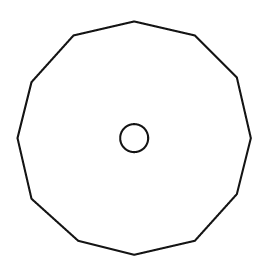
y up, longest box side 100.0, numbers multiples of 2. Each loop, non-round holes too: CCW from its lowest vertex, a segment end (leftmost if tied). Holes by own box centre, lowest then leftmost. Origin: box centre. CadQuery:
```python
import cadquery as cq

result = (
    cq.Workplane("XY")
    .moveTo(0.0, -50.0)
    .lineTo(26.0, -44.0)
    .lineTo(44.0, -24.0)
    .lineTo(50.0, 0.0)
    .lineTo(44.0, 26.0)
    .lineTo(26.0, 44.0)
    .lineTo(0.0, 50.0)
    .lineTo(-26.0, 44.0)
    .lineTo(-44.0, 24.0)
    .lineTo(-50.0, 0.0)
    .lineTo(-44.0, -26.0)
    .lineTo(-24.0, -44.0)
    .close()
    .moveTo(0.0, 0.0)
    .circle(6.0)
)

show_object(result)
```